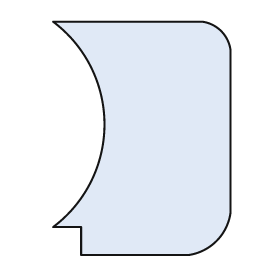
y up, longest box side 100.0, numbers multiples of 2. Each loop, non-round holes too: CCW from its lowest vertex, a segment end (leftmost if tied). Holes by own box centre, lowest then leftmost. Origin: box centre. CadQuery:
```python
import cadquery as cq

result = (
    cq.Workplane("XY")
    .moveTo(-26.0, -50.0)
    .lineTo(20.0, -50.0)
    .threePointArc((32.0, -44.0), (38.0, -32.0))
    .lineTo(38.0, 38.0)
    .threePointArc((34.0, 46.0), (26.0, 50.0))
    .lineTo(-38.0, 50.0)
    .threePointArc((-16.0, 6.0), (-38.0, -38.0))
    .lineTo(-26.0, -38.0)
    .close()
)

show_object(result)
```